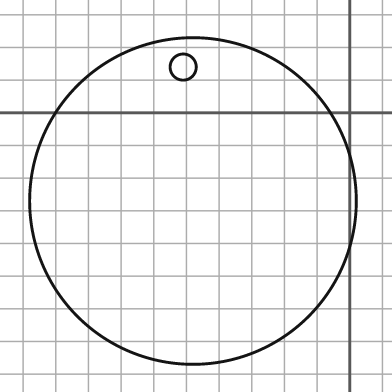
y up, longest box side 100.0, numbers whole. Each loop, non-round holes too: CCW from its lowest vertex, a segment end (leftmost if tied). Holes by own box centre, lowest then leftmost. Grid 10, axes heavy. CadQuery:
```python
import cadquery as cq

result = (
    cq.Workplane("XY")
    .moveTo(-48.0, -27.0)
    .circle(50.0)
    .moveTo(-51.0, 14.0)
    .circle(4.0)
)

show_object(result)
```